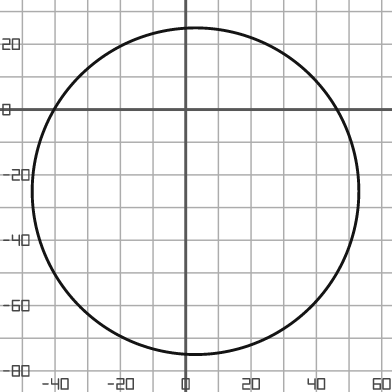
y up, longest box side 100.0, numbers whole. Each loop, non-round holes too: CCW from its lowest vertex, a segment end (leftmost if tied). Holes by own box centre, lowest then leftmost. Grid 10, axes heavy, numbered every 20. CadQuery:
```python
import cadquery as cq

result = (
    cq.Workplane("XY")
    .moveTo(3.0, -25.0)
    .circle(50.0)
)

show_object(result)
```